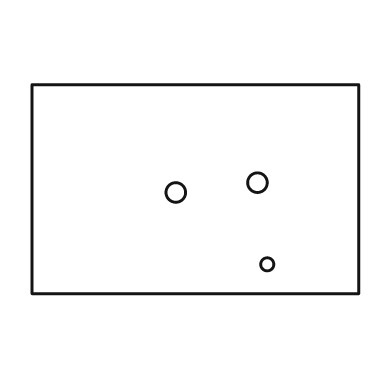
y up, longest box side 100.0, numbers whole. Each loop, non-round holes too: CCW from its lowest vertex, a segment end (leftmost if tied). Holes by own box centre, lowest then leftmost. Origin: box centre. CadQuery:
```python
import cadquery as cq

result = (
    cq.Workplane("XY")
    .moveTo(-50.0, -32.0)
    .lineTo(50.0, -32.0)
    .lineTo(50.0, 32.0)
    .lineTo(-50.0, 32.0)
    .close()
    .moveTo(22.0, -23.0)
    .circle(2.0)
    .moveTo(-6.0, -1.0)
    .circle(3.0)
    .moveTo(19.0, 2.0)
    .circle(3.0)
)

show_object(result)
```